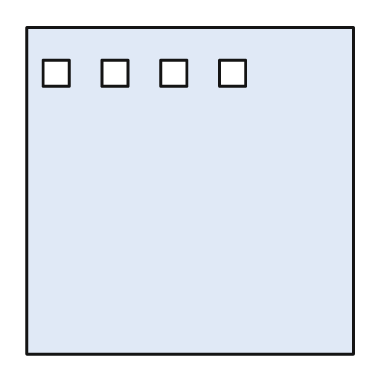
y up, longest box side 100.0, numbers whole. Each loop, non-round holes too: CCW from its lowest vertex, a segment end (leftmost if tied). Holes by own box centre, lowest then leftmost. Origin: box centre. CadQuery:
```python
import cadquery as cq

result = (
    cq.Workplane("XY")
    .moveTo(-50.0, -50.0)
    .lineTo(50.0, -50.0)
    .lineTo(50.0, 50.0)
    .lineTo(-50.0, 50.0)
    .close()
    .moveTo(-45.0, 32.0)
    .lineTo(-37.0, 32.0)
    .lineTo(-37.0, 40.0)
    .lineTo(-45.0, 40.0)
    .close()
    .moveTo(-27.0, 32.0)
    .lineTo(-19.0, 32.0)
    .lineTo(-19.0, 40.0)
    .lineTo(-27.0, 40.0)
    .close()
    .moveTo(-9.0, 32.0)
    .lineTo(-1.0, 32.0)
    .lineTo(-1.0, 40.0)
    .lineTo(-9.0, 40.0)
    .close()
    .moveTo(9.0, 32.0)
    .lineTo(17.0, 32.0)
    .lineTo(17.0, 40.0)
    .lineTo(9.0, 40.0)
    .close()
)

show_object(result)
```